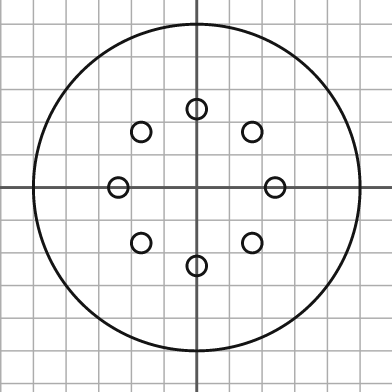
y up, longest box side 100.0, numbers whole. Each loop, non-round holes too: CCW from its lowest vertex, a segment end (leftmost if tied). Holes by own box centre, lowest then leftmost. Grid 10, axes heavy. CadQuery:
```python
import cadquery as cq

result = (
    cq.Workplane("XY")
    .moveTo(0.0, 0.0)
    .circle(50.0)
    .moveTo(0.0, -24.0)
    .circle(3.0)
    .moveTo(-17.0, -17.0)
    .circle(3.0)
    .moveTo(17.0, -17.0)
    .circle(3.0)
    .moveTo(-24.0, 0.0)
    .circle(3.0)
    .moveTo(24.0, 0.0)
    .circle(3.0)
    .moveTo(-17.0, 17.0)
    .circle(3.0)
    .moveTo(17.0, 17.0)
    .circle(3.0)
    .moveTo(0.0, 24.0)
    .circle(3.0)
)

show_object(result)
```